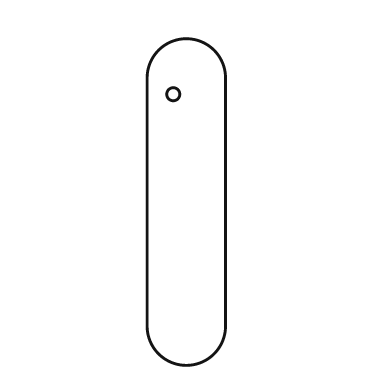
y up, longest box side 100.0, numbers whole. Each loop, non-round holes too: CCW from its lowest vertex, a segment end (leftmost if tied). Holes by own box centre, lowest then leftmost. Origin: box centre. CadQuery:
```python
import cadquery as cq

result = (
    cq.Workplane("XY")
    .moveTo(-12.0, -38.0)
    .threePointArc((0.0, -50.0), (12.0, -38.0))
    .lineTo(12.0, 38.0)
    .threePointArc((0.0, 50.0), (-12.0, 38.0))
    .close()
    .moveTo(-4.0, 33.0)
    .circle(2.0)
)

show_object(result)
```